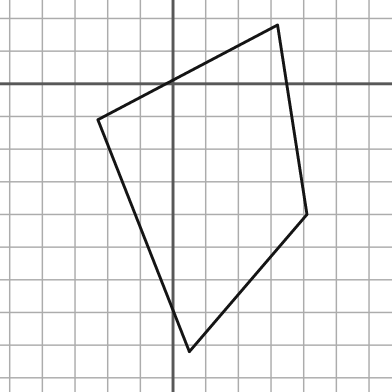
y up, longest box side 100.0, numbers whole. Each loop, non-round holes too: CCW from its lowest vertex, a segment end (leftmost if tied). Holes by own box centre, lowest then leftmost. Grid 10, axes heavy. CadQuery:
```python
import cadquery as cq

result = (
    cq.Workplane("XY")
    .moveTo(5.0, -82.0)
    .lineTo(41.0, -40.0)
    .lineTo(32.0, 18.0)
    .lineTo(-23.0, -11.0)
    .close()
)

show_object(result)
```